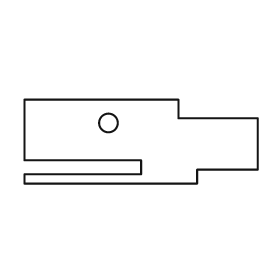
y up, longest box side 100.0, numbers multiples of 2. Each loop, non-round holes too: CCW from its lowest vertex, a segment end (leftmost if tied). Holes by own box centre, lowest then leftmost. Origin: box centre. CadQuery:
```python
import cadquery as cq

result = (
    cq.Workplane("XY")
    .moveTo(-50.0, -18.0)
    .lineTo(24.0, -18.0)
    .lineTo(24.0, -12.0)
    .lineTo(50.0, -12.0)
    .lineTo(50.0, 10.0)
    .lineTo(16.0, 10.0)
    .lineTo(16.0, 18.0)
    .lineTo(-50.0, 18.0)
    .lineTo(-50.0, -8.0)
    .lineTo(0.0, -8.0)
    .lineTo(0.0, -14.0)
    .lineTo(-50.0, -14.0)
    .close()
    .moveTo(-14.0, 8.0)
    .circle(4.0)
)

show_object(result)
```